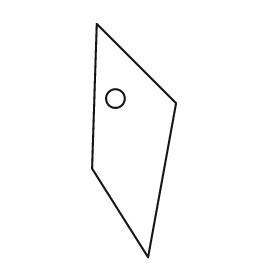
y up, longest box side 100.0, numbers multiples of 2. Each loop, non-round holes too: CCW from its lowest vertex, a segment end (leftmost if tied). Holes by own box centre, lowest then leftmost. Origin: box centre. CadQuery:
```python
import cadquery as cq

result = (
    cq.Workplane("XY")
    .moveTo(6.0, -50.0)
    .lineTo(18.0, 16.0)
    .lineTo(-16.0, 50.0)
    .lineTo(-18.0, -12.0)
    .close()
    .moveTo(-8.0, 18.0)
    .circle(4.0)
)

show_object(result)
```